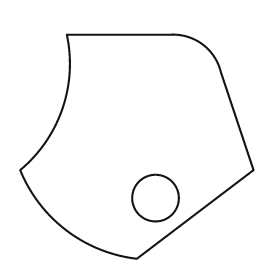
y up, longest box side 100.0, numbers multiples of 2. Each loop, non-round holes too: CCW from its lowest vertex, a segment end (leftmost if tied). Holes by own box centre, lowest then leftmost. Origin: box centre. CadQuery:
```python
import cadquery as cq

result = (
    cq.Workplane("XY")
    .moveTo(0.0, -48.0)
    .lineTo(50.0, -10.0)
    .lineTo(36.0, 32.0)
    .threePointArc((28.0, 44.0), (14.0, 48.0))
    .lineTo(-30.0, 48.0)
    .threePointArc((-32.0, 16.0), (-50.0, -10.0))
    .threePointArc((-30.0, -36.0), (0.0, -48.0))
    .close()
    .moveTo(8.0, -22.0)
    .circle(10.0)
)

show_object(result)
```